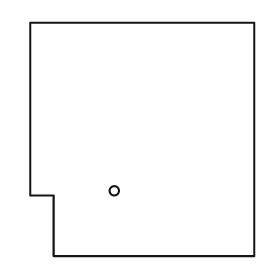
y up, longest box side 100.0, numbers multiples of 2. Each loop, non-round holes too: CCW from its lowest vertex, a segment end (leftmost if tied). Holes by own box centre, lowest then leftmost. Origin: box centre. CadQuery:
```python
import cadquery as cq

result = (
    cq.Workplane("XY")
    .moveTo(-38.0, -50.0)
    .lineTo(48.0, -50.0)
    .lineTo(48.0, 50.0)
    .lineTo(-48.0, 50.0)
    .lineTo(-48.0, -24.0)
    .lineTo(-38.0, -24.0)
    .close()
    .moveTo(-12.0, -22.0)
    .circle(2.0)
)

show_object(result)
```